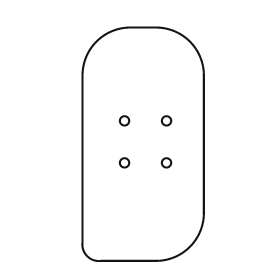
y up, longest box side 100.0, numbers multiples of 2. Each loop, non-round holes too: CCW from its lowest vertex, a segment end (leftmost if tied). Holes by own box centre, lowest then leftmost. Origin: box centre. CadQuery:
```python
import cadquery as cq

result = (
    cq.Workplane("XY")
    .moveTo(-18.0, -50.0)
    .lineTo(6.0, -50.0)
    .threePointArc((20.0, -44.0), (26.0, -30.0))
    .lineTo(26.0, 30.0)
    .threePointArc((20.0, 44.0), (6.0, 50.0))
    .lineTo(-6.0, 50.0)
    .threePointArc((-20.0, 44.0), (-26.0, 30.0))
    .lineTo(-26.0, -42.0)
    .threePointArc((-24.0, -48.0), (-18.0, -50.0))
    .close()
    .moveTo(-8.0, -8.0)
    .circle(2.0)
    .moveTo(10.0, -8.0)
    .circle(2.0)
    .moveTo(-8.0, 10.0)
    .circle(2.0)
    .moveTo(10.0, 10.0)
    .circle(2.0)
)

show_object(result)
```